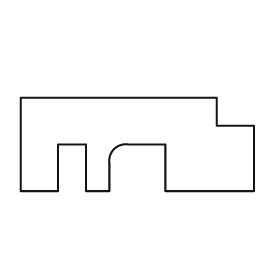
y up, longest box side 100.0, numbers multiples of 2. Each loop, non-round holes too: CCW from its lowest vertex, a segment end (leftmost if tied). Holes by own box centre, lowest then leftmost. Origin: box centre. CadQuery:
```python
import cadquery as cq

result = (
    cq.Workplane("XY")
    .moveTo(-50.0, -20.0)
    .lineTo(-34.0, -20.0)
    .lineTo(-34.0, 0.0)
    .lineTo(-22.0, 0.0)
    .lineTo(-22.0, -20.0)
    .lineTo(-12.0, -20.0)
    .lineTo(-12.0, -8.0)
    .threePointArc((-10.0, -2.0), (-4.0, 0.0))
    .lineTo(12.0, 0.0)
    .lineTo(12.0, -20.0)
    .lineTo(50.0, -20.0)
    .lineTo(50.0, 8.0)
    .lineTo(34.0, 8.0)
    .lineTo(34.0, 20.0)
    .lineTo(-50.0, 20.0)
    .close()
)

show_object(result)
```